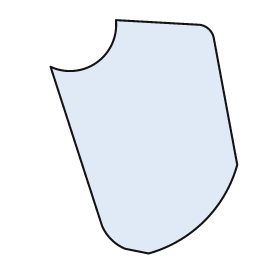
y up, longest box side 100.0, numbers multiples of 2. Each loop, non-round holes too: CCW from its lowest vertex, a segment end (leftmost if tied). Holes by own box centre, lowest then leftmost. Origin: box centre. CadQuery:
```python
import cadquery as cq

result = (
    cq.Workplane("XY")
    .moveTo(2.0, -50.0)
    .threePointArc((26.0, -36.0), (40.0, -12.0))
    .lineTo(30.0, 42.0)
    .threePointArc((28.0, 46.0), (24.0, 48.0))
    .lineTo(-12.0, 50.0)
    .threePointArc((-20.0, 32.0), (-40.0, 30.0))
    .lineTo(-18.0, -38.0)
    .threePointArc((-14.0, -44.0), (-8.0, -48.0))
    .close()
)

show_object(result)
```